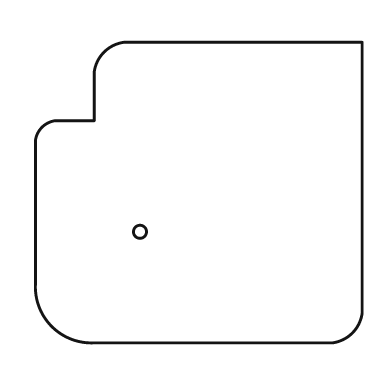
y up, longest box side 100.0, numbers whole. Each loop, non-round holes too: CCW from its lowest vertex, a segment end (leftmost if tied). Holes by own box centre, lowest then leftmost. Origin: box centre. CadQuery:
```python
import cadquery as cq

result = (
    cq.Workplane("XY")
    .moveTo(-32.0, -46.0)
    .lineTo(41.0, -46.0)
    .threePointArc((47.0, -43.0), (50.0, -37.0))
    .lineTo(50.0, 46.0)
    .lineTo(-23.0, 46.0)
    .threePointArc((-29.0, 43.0), (-32.0, 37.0))
    .lineTo(-32.0, 22.0)
    .lineTo(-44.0, 22.0)
    .threePointArc((-48.0, 20.0), (-50.0, 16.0))
    .lineTo(-50.0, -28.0)
    .threePointArc((-45.0, -41.0), (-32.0, -46.0))
    .close()
    .moveTo(-18.0, -12.0)
    .circle(2.0)
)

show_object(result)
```